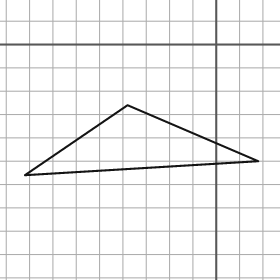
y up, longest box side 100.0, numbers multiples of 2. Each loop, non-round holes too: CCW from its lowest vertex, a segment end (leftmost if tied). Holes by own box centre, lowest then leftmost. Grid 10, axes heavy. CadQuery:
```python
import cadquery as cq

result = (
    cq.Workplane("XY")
    .moveTo(-82.0, -56.0)
    .lineTo(18.0, -50.0)
    .lineTo(-38.0, -26.0)
    .close()
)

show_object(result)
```